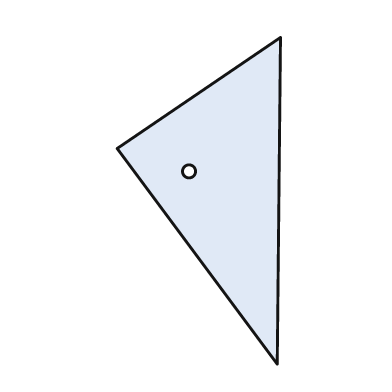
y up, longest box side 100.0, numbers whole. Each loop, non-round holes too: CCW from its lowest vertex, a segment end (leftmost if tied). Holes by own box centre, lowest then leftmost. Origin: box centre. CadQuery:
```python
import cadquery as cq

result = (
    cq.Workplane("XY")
    .moveTo(24.0, -50.0)
    .lineTo(25.0, 50.0)
    .lineTo(-25.0, 16.0)
    .close()
    .moveTo(-3.0, 9.0)
    .circle(2.0)
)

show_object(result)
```